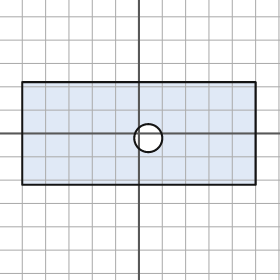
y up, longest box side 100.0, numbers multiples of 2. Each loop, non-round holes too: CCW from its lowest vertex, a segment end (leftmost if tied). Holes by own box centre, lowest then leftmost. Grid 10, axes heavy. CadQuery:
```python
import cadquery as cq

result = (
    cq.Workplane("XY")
    .moveTo(-50.0, -22.0)
    .lineTo(50.0, -22.0)
    .lineTo(50.0, 22.0)
    .lineTo(-50.0, 22.0)
    .close()
    .moveTo(4.0, -2.0)
    .circle(6.0)
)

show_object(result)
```